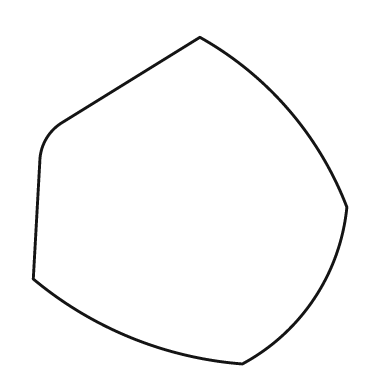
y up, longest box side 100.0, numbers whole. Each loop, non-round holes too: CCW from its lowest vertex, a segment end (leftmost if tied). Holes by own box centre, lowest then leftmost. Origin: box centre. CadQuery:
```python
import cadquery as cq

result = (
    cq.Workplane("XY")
    .moveTo(16.0, -50.0)
    .threePointArc((38.0, -30.0), (48.0, -2.0))
    .threePointArc((30.0, 28.0), (3.0, 50.0))
    .lineTo(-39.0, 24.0)
    .threePointArc((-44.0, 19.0), (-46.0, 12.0))
    .lineTo(-48.0, -24.0)
    .threePointArc((-18.0, -42.0), (16.0, -50.0))
    .close()
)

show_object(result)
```